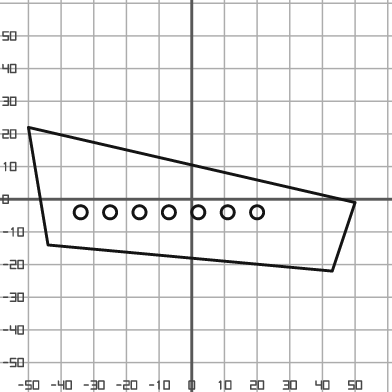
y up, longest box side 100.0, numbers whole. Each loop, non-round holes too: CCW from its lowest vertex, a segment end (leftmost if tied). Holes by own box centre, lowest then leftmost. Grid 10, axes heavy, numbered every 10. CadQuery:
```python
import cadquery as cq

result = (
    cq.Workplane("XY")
    .moveTo(43.0, -22.0)
    .lineTo(50.0, -1.0)
    .lineTo(-50.0, 22.0)
    .lineTo(-44.0, -14.0)
    .close()
    .moveTo(-34.0, -4.0)
    .circle(2.0)
    .moveTo(-25.0, -4.0)
    .circle(2.0)
    .moveTo(-16.0, -4.0)
    .circle(2.0)
    .moveTo(-7.0, -4.0)
    .circle(2.0)
    .moveTo(2.0, -4.0)
    .circle(2.0)
    .moveTo(11.0, -4.0)
    .circle(2.0)
    .moveTo(20.0, -4.0)
    .circle(2.0)
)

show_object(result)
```